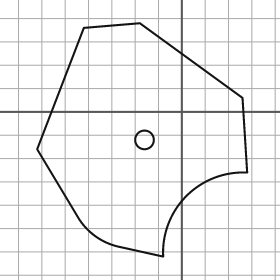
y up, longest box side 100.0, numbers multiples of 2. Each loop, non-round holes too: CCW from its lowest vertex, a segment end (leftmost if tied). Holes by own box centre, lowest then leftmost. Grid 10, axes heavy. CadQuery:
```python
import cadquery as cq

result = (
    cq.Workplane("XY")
    .moveTo(-8.0, -62.0)
    .threePointArc((2.0, -36.0), (28.0, -26.0))
    .lineTo(26.0, 6.0)
    .lineTo(-18.0, 38.0)
    .lineTo(-42.0, 36.0)
    .lineTo(-62.0, -16.0)
    .lineTo(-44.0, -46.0)
    .threePointArc((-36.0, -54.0), (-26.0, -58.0))
    .close()
    .moveTo(-16.0, -12.0)
    .circle(4.0)
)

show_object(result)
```